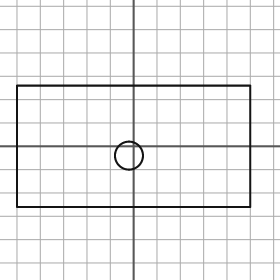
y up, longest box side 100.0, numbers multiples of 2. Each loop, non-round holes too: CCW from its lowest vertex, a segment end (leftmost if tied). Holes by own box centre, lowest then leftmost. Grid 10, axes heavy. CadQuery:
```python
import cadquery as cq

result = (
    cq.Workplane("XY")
    .moveTo(-50.0, -26.0)
    .lineTo(50.0, -26.0)
    .lineTo(50.0, 26.0)
    .lineTo(-50.0, 26.0)
    .close()
    .moveTo(-2.0, -4.0)
    .circle(6.0)
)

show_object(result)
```